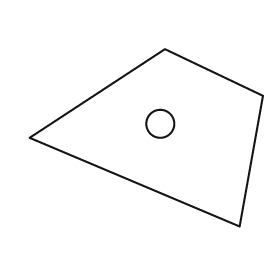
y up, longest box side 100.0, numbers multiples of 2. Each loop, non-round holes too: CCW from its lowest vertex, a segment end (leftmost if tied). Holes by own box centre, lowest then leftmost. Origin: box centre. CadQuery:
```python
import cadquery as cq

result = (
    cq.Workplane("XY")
    .moveTo(40.0, -38.0)
    .lineTo(50.0, 18.0)
    .lineTo(8.0, 38.0)
    .lineTo(-50.0, 0.0)
    .close()
    .moveTo(6.0, 6.0)
    .circle(6.0)
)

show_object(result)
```